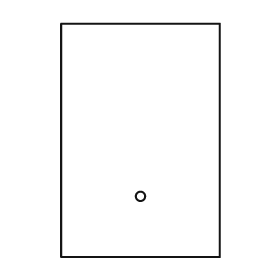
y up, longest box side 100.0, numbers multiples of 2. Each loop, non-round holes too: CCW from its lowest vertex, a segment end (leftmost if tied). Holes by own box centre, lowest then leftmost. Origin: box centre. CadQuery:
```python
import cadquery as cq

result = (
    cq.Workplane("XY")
    .moveTo(-34.0, -50.0)
    .lineTo(34.0, -50.0)
    .lineTo(34.0, 50.0)
    .lineTo(-34.0, 50.0)
    .close()
    .moveTo(0.0, -24.0)
    .circle(2.0)
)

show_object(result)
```